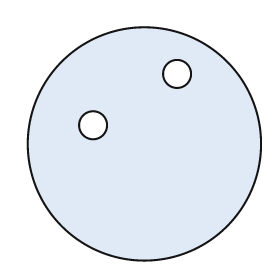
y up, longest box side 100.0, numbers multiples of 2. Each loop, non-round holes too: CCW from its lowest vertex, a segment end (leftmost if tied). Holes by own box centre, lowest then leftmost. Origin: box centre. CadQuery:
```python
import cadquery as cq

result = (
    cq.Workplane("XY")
    .moveTo(0.0, 0.0)
    .circle(50.0)
    .moveTo(-22.0, 8.0)
    .circle(6.0)
    .moveTo(14.0, 30.0)
    .circle(6.0)
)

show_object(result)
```